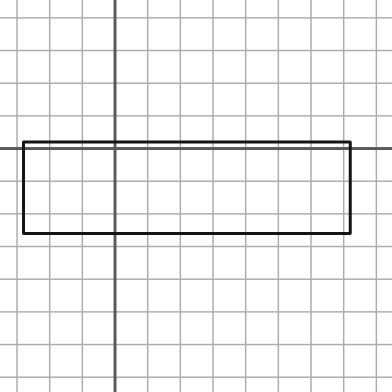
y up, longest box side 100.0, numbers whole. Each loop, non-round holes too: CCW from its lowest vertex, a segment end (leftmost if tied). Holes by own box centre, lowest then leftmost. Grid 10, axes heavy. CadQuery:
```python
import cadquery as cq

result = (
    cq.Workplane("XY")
    .moveTo(-28.0, -26.0)
    .lineTo(72.0, -26.0)
    .lineTo(72.0, 2.0)
    .lineTo(-28.0, 2.0)
    .close()
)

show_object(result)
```